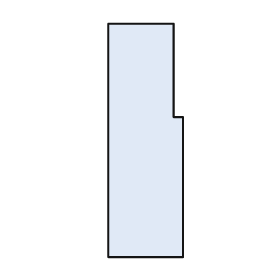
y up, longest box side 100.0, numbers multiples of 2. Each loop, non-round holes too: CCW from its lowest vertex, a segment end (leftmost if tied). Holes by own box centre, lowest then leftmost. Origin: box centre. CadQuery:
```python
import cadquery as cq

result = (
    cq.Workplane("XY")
    .moveTo(-16.0, -50.0)
    .lineTo(16.0, -50.0)
    .lineTo(16.0, 10.0)
    .lineTo(12.0, 10.0)
    .lineTo(12.0, 50.0)
    .lineTo(-16.0, 50.0)
    .close()
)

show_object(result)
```